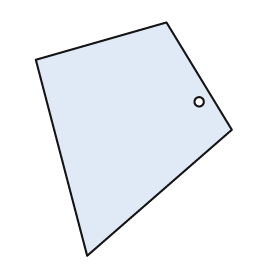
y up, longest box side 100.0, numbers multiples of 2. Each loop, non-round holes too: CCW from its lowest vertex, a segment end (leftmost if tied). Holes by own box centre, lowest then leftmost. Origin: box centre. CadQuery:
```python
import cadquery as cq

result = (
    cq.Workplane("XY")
    .moveTo(-20.0, -50.0)
    .lineTo(42.0, 4.0)
    .lineTo(14.0, 50.0)
    .lineTo(-42.0, 34.0)
    .close()
    .moveTo(28.0, 16.0)
    .circle(2.0)
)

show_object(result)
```